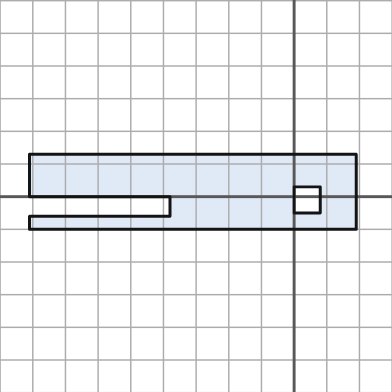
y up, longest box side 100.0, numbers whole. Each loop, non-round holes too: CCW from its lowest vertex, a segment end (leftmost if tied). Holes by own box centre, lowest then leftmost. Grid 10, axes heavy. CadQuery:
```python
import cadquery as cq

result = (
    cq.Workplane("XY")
    .moveTo(-81.0, -10.0)
    .lineTo(19.0, -10.0)
    .lineTo(19.0, 13.0)
    .lineTo(-81.0, 13.0)
    .lineTo(-81.0, 0.0)
    .lineTo(-38.0, 0.0)
    .lineTo(-38.0, -6.0)
    .lineTo(-81.0, -6.0)
    .close()
    .moveTo(0.0, -5.0)
    .lineTo(8.0, -5.0)
    .lineTo(8.0, 3.0)
    .lineTo(0.0, 3.0)
    .close()
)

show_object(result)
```